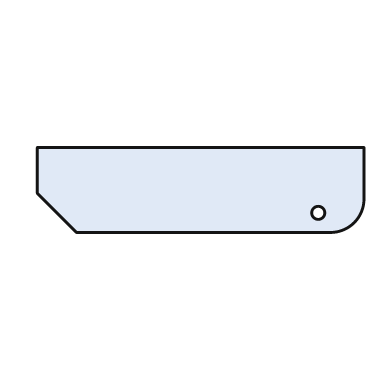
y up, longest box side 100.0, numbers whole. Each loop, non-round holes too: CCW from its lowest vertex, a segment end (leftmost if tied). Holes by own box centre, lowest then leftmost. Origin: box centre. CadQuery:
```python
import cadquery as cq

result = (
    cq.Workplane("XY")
    .moveTo(-38.0, -13.0)
    .lineTo(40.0, -13.0)
    .threePointArc((47.0, -10.0), (50.0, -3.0))
    .lineTo(50.0, 13.0)
    .lineTo(-50.0, 13.0)
    .lineTo(-50.0, -1.0)
    .close()
    .moveTo(36.0, -7.0)
    .circle(2.0)
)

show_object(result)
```